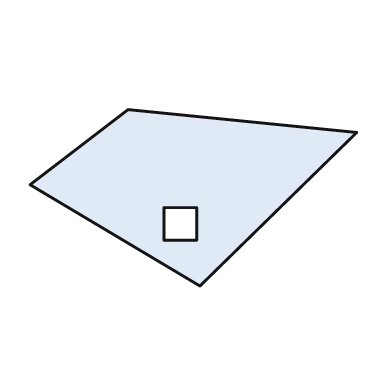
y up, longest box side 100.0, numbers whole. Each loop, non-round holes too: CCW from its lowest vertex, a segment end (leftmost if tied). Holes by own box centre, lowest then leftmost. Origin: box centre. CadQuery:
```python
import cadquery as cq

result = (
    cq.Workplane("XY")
    .moveTo(2.0, -27.0)
    .lineTo(50.0, 20.0)
    .lineTo(-20.0, 27.0)
    .lineTo(-50.0, 4.0)
    .close()
    .moveTo(-9.0, -13.0)
    .lineTo(1.0, -13.0)
    .lineTo(1.0, -3.0)
    .lineTo(-9.0, -3.0)
    .close()
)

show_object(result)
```